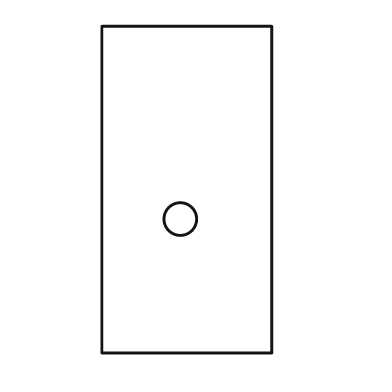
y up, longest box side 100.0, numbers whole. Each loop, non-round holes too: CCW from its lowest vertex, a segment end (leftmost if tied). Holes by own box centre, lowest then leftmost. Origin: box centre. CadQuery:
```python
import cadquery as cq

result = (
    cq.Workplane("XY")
    .moveTo(-26.0, -50.0)
    .lineTo(26.0, -50.0)
    .lineTo(26.0, 50.0)
    .lineTo(-26.0, 50.0)
    .close()
    .moveTo(-2.0, -9.0)
    .circle(5.0)
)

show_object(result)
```